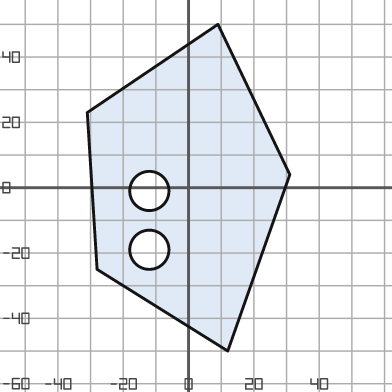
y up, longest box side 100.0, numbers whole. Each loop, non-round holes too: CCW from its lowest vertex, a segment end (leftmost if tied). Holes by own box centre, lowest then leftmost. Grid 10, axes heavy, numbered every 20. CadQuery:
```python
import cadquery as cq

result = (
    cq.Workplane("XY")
    .moveTo(12.0, -50.0)
    .lineTo(31.0, 4.0)
    .lineTo(9.0, 50.0)
    .lineTo(-31.0, 23.0)
    .lineTo(-28.0, -25.0)
    .close()
    .moveTo(-12.0, -19.0)
    .circle(6.0)
    .moveTo(-12.0, -1.0)
    .circle(6.0)
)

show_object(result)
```